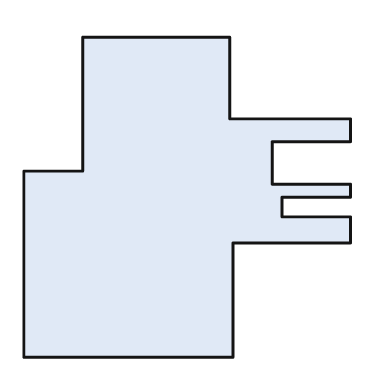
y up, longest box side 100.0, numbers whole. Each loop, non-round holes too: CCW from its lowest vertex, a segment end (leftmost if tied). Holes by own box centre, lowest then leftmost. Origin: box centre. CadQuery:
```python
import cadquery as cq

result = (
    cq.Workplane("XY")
    .moveTo(-50.0, -49.0)
    .lineTo(14.0, -49.0)
    .lineTo(14.0, -14.0)
    .lineTo(50.0, -14.0)
    .lineTo(50.0, -6.0)
    .lineTo(29.0, -6.0)
    .lineTo(29.0, 0.0)
    .lineTo(50.0, 0.0)
    .lineTo(50.0, 4.0)
    .lineTo(26.0, 4.0)
    .lineTo(26.0, 17.0)
    .lineTo(50.0, 17.0)
    .lineTo(50.0, 24.0)
    .lineTo(13.0, 24.0)
    .lineTo(13.0, 49.0)
    .lineTo(-32.0, 49.0)
    .lineTo(-32.0, 8.0)
    .lineTo(-50.0, 8.0)
    .close()
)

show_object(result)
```